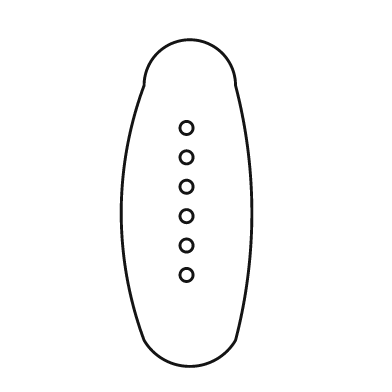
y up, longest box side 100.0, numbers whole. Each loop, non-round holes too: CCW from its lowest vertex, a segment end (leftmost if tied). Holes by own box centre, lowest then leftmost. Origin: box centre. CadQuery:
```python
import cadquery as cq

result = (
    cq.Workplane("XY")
    .moveTo(-13.0, -42.0)
    .threePointArc((1.0, -50.0), (15.0, -42.0))
    .threePointArc((20.0, -3.0), (15.0, 36.0))
    .threePointArc((1.0, 50.0), (-13.0, 36.0))
    .threePointArc((-20.0, -3.0), (-13.0, -42.0))
    .close()
    .moveTo(0.0, -22.0)
    .circle(2.0)
    .moveTo(0.0, -13.0)
    .circle(2.0)
    .moveTo(0.0, -4.0)
    .circle(2.0)
    .moveTo(0.0, 5.0)
    .circle(2.0)
    .moveTo(0.0, 14.0)
    .circle(2.0)
    .moveTo(0.0, 23.0)
    .circle(2.0)
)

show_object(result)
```